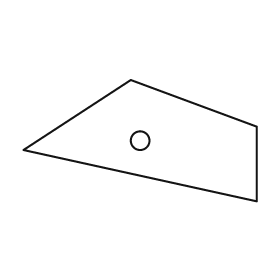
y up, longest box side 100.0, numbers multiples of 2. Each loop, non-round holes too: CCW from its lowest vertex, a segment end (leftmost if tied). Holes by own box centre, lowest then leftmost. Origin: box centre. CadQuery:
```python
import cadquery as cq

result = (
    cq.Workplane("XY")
    .moveTo(50.0, -26.0)
    .lineTo(50.0, 6.0)
    .lineTo(-4.0, 26.0)
    .lineTo(-50.0, -4.0)
    .close()
    .moveTo(0.0, 0.0)
    .circle(4.0)
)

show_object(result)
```